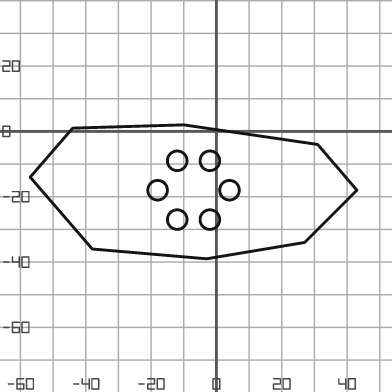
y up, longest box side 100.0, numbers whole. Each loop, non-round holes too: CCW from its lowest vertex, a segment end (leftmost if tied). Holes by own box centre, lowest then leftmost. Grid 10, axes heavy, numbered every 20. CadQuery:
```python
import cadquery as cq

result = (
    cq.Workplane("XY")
    .moveTo(-3.0, -39.0)
    .lineTo(27.0, -34.0)
    .lineTo(43.0, -18.0)
    .lineTo(31.0, -4.0)
    .lineTo(-10.0, 2.0)
    .lineTo(-44.0, 1.0)
    .lineTo(-57.0, -14.0)
    .lineTo(-38.0, -36.0)
    .close()
    .moveTo(-12.0, -27.0)
    .circle(3.0)
    .moveTo(-2.0, -27.0)
    .circle(3.0)
    .moveTo(-18.0, -18.0)
    .circle(3.0)
    .moveTo(4.0, -18.0)
    .circle(3.0)
    .moveTo(-12.0, -9.0)
    .circle(3.0)
    .moveTo(-2.0, -9.0)
    .circle(3.0)
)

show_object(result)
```